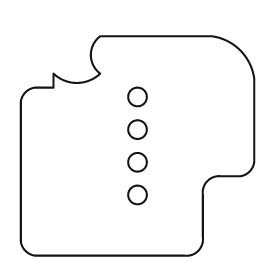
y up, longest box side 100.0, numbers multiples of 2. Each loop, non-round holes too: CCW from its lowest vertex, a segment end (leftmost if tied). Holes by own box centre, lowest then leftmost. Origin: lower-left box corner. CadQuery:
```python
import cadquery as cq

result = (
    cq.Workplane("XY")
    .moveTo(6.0, 0.0)
    .lineTo(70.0, 0.0)
    .threePointArc((76.0, 2.0), (78.0, 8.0))
    .lineTo(78.0, 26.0)
    .threePointArc((80.0, 32.0), (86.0, 34.0))
    .lineTo(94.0, 34.0)
    .threePointArc((98.0, 36.0), (100.0, 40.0))
    .lineTo(100.0, 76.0)
    .threePointArc((94.0, 88.0), (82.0, 94.0))
    .lineTo(34.0, 94.0)
    .threePointArc((30.0, 86.0), (34.0, 78.0))
    .threePointArc((24.0, 74.0), (14.0, 78.0))
    .lineTo(14.0, 72.0)
    .lineTo(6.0, 72.0)
    .threePointArc((2.0, 70.0), (0.0, 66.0))
    .lineTo(0.0, 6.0)
    .threePointArc((2.0, 2.0), (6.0, 0.0))
    .close()
    .moveTo(50.0, 26.0)
    .circle(4.0)
    .moveTo(50.0, 40.0)
    .circle(4.0)
    .moveTo(50.0, 54.0)
    .circle(4.0)
    .moveTo(50.0, 68.0)
    .circle(4.0)
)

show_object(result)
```